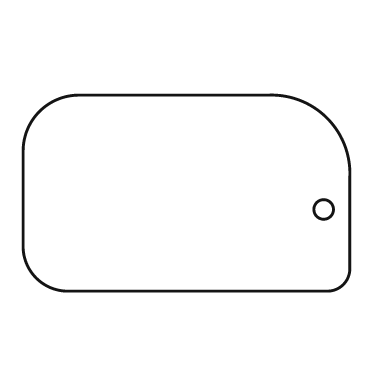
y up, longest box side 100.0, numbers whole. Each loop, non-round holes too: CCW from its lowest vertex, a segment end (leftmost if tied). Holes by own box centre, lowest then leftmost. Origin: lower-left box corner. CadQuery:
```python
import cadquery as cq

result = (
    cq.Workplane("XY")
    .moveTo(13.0, 0.0)
    .lineTo(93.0, 0.0)
    .threePointArc((98.0, 2.0), (100.0, 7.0))
    .lineTo(100.0, 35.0)
    .threePointArc((93.0, 53.0), (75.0, 60.0))
    .lineTo(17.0, 60.0)
    .threePointArc((5.0, 55.0), (0.0, 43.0))
    .lineTo(0.0, 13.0)
    .threePointArc((4.0, 4.0), (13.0, 0.0))
    .close()
    .moveTo(92.0, 25.0)
    .circle(3.0)
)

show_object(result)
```